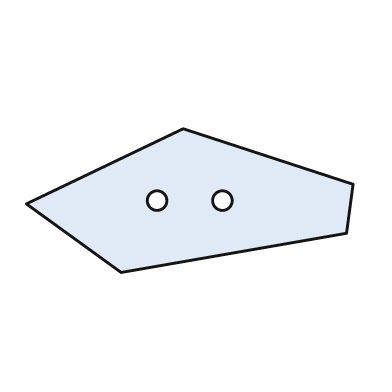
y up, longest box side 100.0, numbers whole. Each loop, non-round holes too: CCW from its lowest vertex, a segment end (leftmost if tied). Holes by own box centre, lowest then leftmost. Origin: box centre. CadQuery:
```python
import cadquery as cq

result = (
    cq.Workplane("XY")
    .moveTo(-21.0, -22.0)
    .lineTo(48.0, -10.0)
    .lineTo(50.0, 5.0)
    .lineTo(-2.0, 22.0)
    .lineTo(-50.0, -1.0)
    .close()
    .moveTo(-10.0, 0.0)
    .circle(3.0)
    .moveTo(10.0, 0.0)
    .circle(3.0)
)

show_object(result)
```